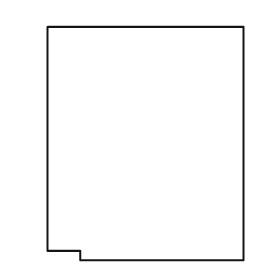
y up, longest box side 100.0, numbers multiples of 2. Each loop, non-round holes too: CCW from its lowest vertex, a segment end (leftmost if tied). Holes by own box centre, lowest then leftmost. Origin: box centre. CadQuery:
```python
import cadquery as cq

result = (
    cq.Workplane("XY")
    .moveTo(-28.0, -50.0)
    .lineTo(42.0, -50.0)
    .lineTo(42.0, 50.0)
    .lineTo(-42.0, 50.0)
    .lineTo(-42.0, -46.0)
    .lineTo(-28.0, -46.0)
    .close()
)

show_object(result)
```